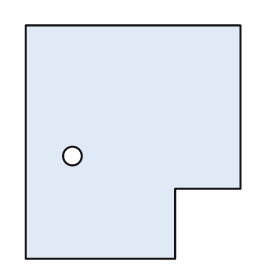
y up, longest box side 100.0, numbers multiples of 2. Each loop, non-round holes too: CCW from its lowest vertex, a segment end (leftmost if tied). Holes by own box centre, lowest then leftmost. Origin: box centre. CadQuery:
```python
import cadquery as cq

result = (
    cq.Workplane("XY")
    .moveTo(-46.0, -50.0)
    .lineTo(18.0, -50.0)
    .lineTo(18.0, -20.0)
    .lineTo(46.0, -20.0)
    .lineTo(46.0, 50.0)
    .lineTo(-46.0, 50.0)
    .close()
    .moveTo(-26.0, -6.0)
    .circle(4.0)
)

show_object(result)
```